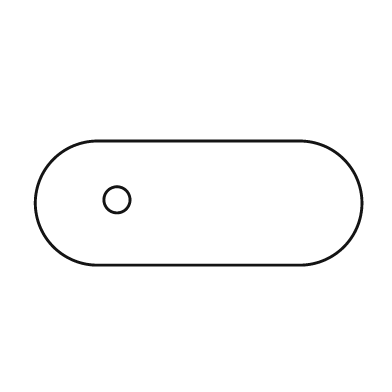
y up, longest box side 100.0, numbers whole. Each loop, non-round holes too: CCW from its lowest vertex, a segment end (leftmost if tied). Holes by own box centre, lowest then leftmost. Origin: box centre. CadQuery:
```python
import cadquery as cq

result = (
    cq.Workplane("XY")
    .moveTo(-31.0, -19.0)
    .lineTo(31.0, -19.0)
    .threePointArc((50.0, 0.0), (31.0, 19.0))
    .lineTo(-31.0, 19.0)
    .threePointArc((-50.0, 0.0), (-31.0, -19.0))
    .close()
    .moveTo(-25.0, 1.0)
    .circle(4.0)
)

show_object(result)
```